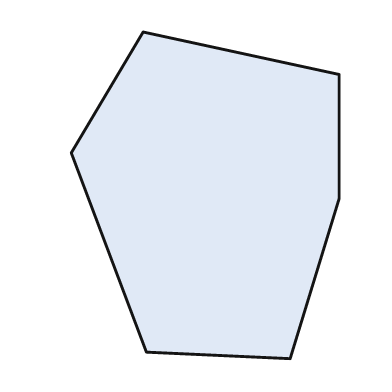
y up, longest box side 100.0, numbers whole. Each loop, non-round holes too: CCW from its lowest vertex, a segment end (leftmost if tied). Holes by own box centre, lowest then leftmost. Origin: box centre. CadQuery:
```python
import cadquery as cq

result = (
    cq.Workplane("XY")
    .moveTo(26.0, -50.0)
    .lineTo(41.0, -1.0)
    .lineTo(41.0, 37.0)
    .lineTo(-19.0, 50.0)
    .lineTo(-41.0, 13.0)
    .lineTo(-18.0, -48.0)
    .close()
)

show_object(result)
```